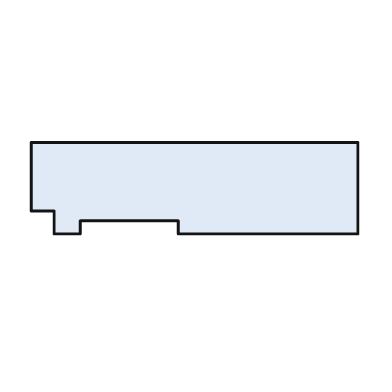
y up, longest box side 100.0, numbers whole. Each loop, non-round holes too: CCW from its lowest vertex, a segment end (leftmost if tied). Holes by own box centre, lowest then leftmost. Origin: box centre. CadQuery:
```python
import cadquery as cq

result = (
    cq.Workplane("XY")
    .moveTo(-43.0, -14.0)
    .lineTo(-35.0, -14.0)
    .lineTo(-35.0, -10.0)
    .lineTo(-5.0, -10.0)
    .lineTo(-5.0, -14.0)
    .lineTo(50.0, -14.0)
    .lineTo(50.0, 14.0)
    .lineTo(-50.0, 14.0)
    .lineTo(-50.0, -7.0)
    .lineTo(-43.0, -7.0)
    .close()
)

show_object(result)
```